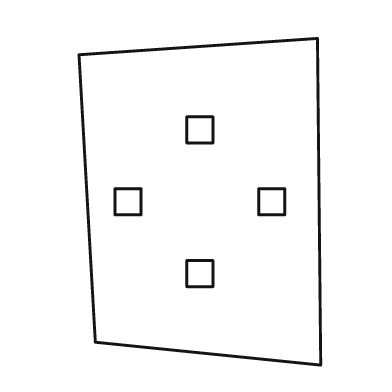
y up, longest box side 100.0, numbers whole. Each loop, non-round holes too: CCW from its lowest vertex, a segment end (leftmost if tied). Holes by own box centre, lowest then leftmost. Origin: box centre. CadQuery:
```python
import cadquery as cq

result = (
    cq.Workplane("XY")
    .moveTo(37.0, -50.0)
    .lineTo(36.0, 50.0)
    .lineTo(-37.0, 45.0)
    .lineTo(-32.0, -43.0)
    .close()
    .moveTo(-4.0, -26.0)
    .lineTo(4.0, -26.0)
    .lineTo(4.0, -18.0)
    .lineTo(-4.0, -18.0)
    .close()
    .moveTo(-26.0, -4.0)
    .lineTo(-18.0, -4.0)
    .lineTo(-18.0, 4.0)
    .lineTo(-26.0, 4.0)
    .close()
    .moveTo(18.0, -4.0)
    .lineTo(26.0, -4.0)
    .lineTo(26.0, 4.0)
    .lineTo(18.0, 4.0)
    .close()
    .moveTo(-4.0, 18.0)
    .lineTo(4.0, 18.0)
    .lineTo(4.0, 26.0)
    .lineTo(-4.0, 26.0)
    .close()
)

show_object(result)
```